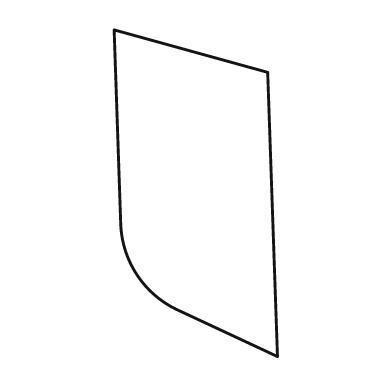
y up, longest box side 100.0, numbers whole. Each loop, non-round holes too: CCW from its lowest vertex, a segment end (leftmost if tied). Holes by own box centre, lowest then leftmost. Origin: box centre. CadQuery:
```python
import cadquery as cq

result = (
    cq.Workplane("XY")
    .moveTo(25.0, -50.0)
    .lineTo(22.0, 37.0)
    .lineTo(-25.0, 50.0)
    .lineTo(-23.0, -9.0)
    .threePointArc((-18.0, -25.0), (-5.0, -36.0))
    .close()
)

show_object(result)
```